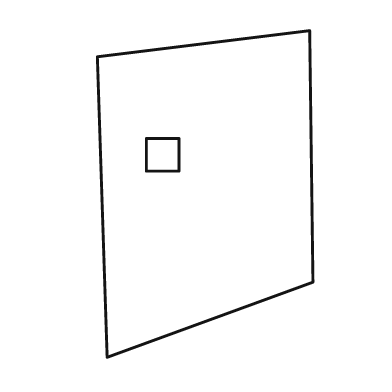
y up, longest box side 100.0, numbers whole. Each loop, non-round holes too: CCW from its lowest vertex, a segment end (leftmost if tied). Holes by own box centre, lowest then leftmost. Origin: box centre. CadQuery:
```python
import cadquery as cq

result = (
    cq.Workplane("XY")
    .moveTo(-30.0, -50.0)
    .lineTo(33.0, -27.0)
    .lineTo(32.0, 50.0)
    .lineTo(-33.0, 42.0)
    .close()
    .moveTo(-18.0, 7.0)
    .lineTo(-8.0, 7.0)
    .lineTo(-8.0, 17.0)
    .lineTo(-18.0, 17.0)
    .close()
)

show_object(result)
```